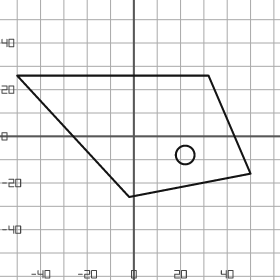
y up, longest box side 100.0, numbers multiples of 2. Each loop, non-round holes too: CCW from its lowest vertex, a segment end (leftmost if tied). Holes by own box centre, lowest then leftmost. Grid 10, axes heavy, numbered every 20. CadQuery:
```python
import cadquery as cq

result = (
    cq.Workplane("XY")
    .moveTo(-2.0, -26.0)
    .lineTo(50.0, -16.0)
    .lineTo(32.0, 26.0)
    .lineTo(-50.0, 26.0)
    .close()
    .moveTo(22.0, -8.0)
    .circle(4.0)
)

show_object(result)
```